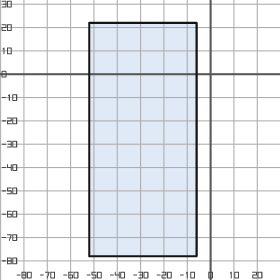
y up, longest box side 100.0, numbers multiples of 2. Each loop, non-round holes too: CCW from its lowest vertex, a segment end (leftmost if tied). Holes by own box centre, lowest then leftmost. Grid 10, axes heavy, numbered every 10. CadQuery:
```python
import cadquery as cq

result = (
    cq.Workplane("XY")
    .moveTo(-52.0, -78.0)
    .lineTo(-6.0, -78.0)
    .lineTo(-6.0, 22.0)
    .lineTo(-52.0, 22.0)
    .close()
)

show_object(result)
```